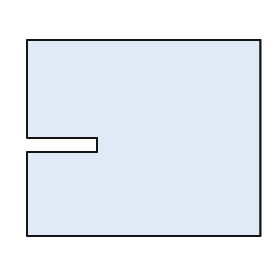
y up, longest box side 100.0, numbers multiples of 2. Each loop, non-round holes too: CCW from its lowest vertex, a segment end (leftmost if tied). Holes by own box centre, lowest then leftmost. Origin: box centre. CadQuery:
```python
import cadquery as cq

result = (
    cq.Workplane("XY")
    .moveTo(-50.0, -42.0)
    .lineTo(50.0, -42.0)
    .lineTo(50.0, 42.0)
    .lineTo(-50.0, 42.0)
    .lineTo(-50.0, 0.0)
    .lineTo(-20.0, 0.0)
    .lineTo(-20.0, -6.0)
    .lineTo(-50.0, -6.0)
    .close()
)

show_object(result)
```